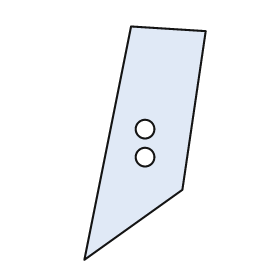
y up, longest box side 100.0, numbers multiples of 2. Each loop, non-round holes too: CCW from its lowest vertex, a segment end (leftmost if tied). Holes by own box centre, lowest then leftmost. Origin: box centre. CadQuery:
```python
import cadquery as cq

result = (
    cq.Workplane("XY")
    .moveTo(-26.0, -50.0)
    .lineTo(16.0, -20.0)
    .lineTo(26.0, 48.0)
    .lineTo(-6.0, 50.0)
    .close()
    .moveTo(0.0, -6.0)
    .circle(4.0)
    .moveTo(0.0, 6.0)
    .circle(4.0)
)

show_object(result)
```